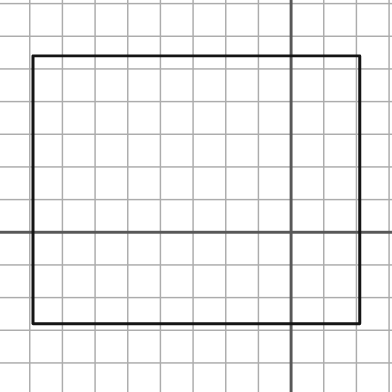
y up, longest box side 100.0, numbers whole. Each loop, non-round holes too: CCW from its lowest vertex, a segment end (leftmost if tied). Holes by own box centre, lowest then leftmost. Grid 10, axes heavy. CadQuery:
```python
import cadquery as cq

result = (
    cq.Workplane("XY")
    .moveTo(-79.0, -28.0)
    .lineTo(21.0, -28.0)
    .lineTo(21.0, 54.0)
    .lineTo(-79.0, 54.0)
    .close()
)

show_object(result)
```